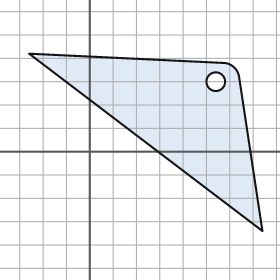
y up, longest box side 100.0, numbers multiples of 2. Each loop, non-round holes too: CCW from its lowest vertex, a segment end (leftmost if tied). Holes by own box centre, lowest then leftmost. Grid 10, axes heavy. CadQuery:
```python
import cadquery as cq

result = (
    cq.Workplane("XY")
    .moveTo(74.0, -34.0)
    .lineTo(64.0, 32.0)
    .threePointArc((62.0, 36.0), (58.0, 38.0))
    .lineTo(-26.0, 42.0)
    .close()
    .moveTo(54.0, 30.0)
    .circle(4.0)
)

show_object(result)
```